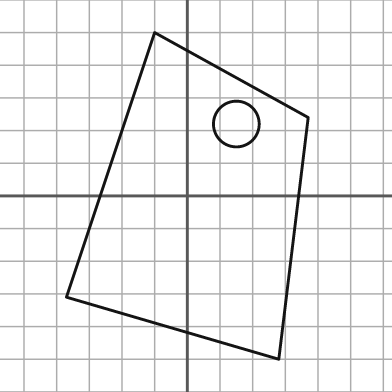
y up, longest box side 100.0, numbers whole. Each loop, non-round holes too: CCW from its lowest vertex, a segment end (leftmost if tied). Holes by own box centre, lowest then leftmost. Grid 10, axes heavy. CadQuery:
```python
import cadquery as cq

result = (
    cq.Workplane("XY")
    .moveTo(28.0, -50.0)
    .lineTo(37.0, 24.0)
    .lineTo(-10.0, 50.0)
    .lineTo(-37.0, -31.0)
    .close()
    .moveTo(15.0, 22.0)
    .circle(7.0)
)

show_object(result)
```